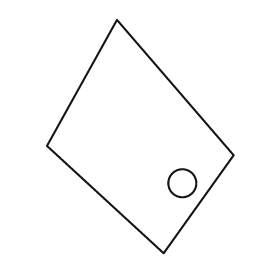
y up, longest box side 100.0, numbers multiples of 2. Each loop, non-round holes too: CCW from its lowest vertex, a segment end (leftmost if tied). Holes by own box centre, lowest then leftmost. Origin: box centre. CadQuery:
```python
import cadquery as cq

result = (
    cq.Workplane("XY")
    .moveTo(10.0, -50.0)
    .lineTo(40.0, -8.0)
    .lineTo(-10.0, 50.0)
    .lineTo(-40.0, -4.0)
    .close()
    .moveTo(18.0, -20.0)
    .circle(6.0)
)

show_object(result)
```